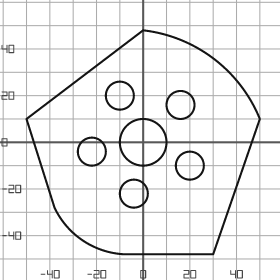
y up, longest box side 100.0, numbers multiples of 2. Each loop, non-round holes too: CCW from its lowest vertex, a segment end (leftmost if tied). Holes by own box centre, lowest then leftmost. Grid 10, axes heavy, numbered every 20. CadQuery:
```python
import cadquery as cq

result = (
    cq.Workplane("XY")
    .moveTo(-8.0, -48.0)
    .lineTo(30.0, -48.0)
    .lineTo(50.0, 10.0)
    .threePointArc((30.0, 36.0), (0.0, 48.0))
    .lineTo(-50.0, 10.0)
    .lineTo(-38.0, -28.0)
    .threePointArc((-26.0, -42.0), (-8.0, -48.0))
    .close()
    .moveTo(-4.0, -22.0)
    .circle(6.0)
    .moveTo(20.0, -10.0)
    .circle(6.0)
    .moveTo(-22.0, -4.0)
    .circle(6.0)
    .moveTo(0.0, 0.0)
    .circle(10.0)
    .moveTo(16.0, 16.0)
    .circle(6.0)
    .moveTo(-10.0, 20.0)
    .circle(6.0)
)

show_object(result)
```